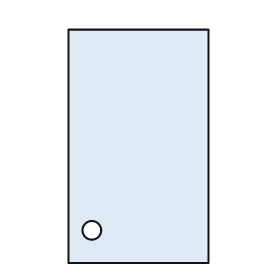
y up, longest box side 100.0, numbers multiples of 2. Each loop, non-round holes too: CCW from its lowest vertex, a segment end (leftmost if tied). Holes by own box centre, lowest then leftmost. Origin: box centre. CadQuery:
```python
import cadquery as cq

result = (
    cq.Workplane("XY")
    .moveTo(-30.0, -50.0)
    .lineTo(30.0, -50.0)
    .lineTo(30.0, 50.0)
    .lineTo(-30.0, 50.0)
    .close()
    .moveTo(-20.0, -36.0)
    .circle(4.0)
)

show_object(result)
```